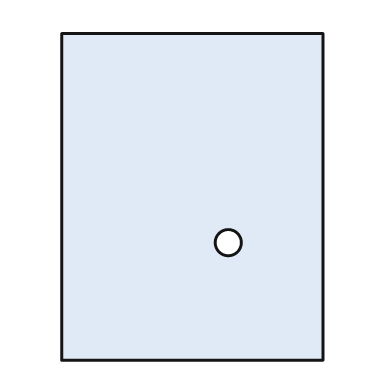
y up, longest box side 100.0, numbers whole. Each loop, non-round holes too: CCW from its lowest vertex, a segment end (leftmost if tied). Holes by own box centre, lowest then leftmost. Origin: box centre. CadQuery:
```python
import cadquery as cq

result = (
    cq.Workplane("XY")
    .moveTo(-40.0, -50.0)
    .lineTo(40.0, -50.0)
    .lineTo(40.0, 50.0)
    .lineTo(-40.0, 50.0)
    .close()
    .moveTo(11.0, -14.0)
    .circle(4.0)
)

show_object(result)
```